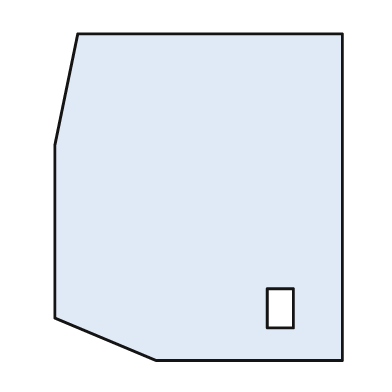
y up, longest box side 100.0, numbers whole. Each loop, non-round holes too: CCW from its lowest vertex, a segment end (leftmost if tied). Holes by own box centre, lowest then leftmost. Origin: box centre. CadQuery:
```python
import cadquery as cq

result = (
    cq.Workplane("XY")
    .moveTo(-13.0, -50.0)
    .lineTo(44.0, -50.0)
    .lineTo(44.0, 50.0)
    .lineTo(-37.0, 50.0)
    .lineTo(-44.0, 16.0)
    .lineTo(-44.0, -37.0)
    .close()
    .moveTo(21.0, -40.0)
    .lineTo(29.0, -40.0)
    .lineTo(29.0, -28.0)
    .lineTo(21.0, -28.0)
    .close()
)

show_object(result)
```